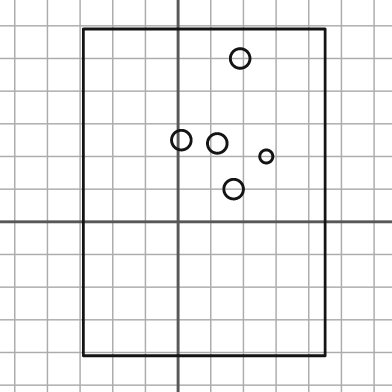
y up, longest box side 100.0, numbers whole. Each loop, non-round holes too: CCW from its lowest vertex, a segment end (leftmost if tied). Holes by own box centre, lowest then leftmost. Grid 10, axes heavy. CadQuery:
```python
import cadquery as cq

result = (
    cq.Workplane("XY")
    .moveTo(-29.0, -41.0)
    .lineTo(45.0, -41.0)
    .lineTo(45.0, 59.0)
    .lineTo(-29.0, 59.0)
    .close()
    .moveTo(17.0, 10.0)
    .circle(3.0)
    .moveTo(27.0, 20.0)
    .circle(2.0)
    .moveTo(12.0, 24.0)
    .circle(3.0)
    .moveTo(1.0, 25.0)
    .circle(3.0)
    .moveTo(19.0, 50.0)
    .circle(3.0)
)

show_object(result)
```